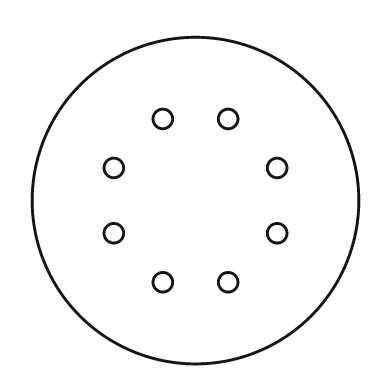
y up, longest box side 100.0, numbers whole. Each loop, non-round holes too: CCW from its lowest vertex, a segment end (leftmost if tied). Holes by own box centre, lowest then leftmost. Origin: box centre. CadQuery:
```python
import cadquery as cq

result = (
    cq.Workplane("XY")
    .moveTo(0.0, 0.0)
    .circle(50.0)
    .moveTo(-10.0, -25.0)
    .circle(3.0)
    .moveTo(10.0, -25.0)
    .circle(3.0)
    .moveTo(-25.0, -10.0)
    .circle(3.0)
    .moveTo(25.0, -10.0)
    .circle(3.0)
    .moveTo(-25.0, 10.0)
    .circle(3.0)
    .moveTo(25.0, 10.0)
    .circle(3.0)
    .moveTo(-10.0, 25.0)
    .circle(3.0)
    .moveTo(10.0, 25.0)
    .circle(3.0)
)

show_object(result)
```